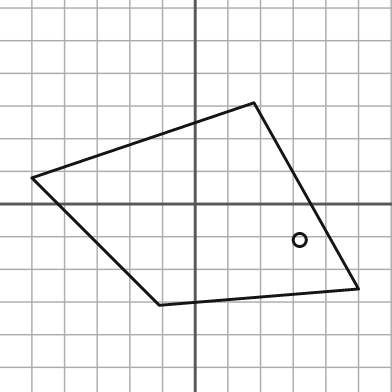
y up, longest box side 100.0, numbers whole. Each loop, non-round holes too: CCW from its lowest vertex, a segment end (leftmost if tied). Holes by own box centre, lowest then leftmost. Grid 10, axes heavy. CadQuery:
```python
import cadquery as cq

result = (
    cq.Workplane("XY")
    .moveTo(-11.0, -31.0)
    .lineTo(50.0, -26.0)
    .lineTo(18.0, 31.0)
    .lineTo(-50.0, 8.0)
    .close()
    .moveTo(32.0, -11.0)
    .circle(2.0)
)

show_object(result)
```